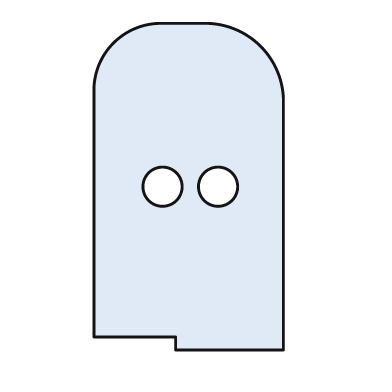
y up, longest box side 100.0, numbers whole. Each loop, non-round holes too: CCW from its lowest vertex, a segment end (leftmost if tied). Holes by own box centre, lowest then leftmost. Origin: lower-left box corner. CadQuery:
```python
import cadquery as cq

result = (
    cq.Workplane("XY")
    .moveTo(25.0, 0.0)
    .lineTo(58.0, 0.0)
    .lineTo(58.0, 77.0)
    .threePointArc((51.0, 93.0), (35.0, 100.0))
    .lineTo(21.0, 100.0)
    .threePointArc((6.0, 94.0), (0.0, 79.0))
    .lineTo(0.0, 4.0)
    .lineTo(25.0, 4.0)
    .close()
    .moveTo(21.0, 50.0)
    .circle(6.0)
    .moveTo(38.0, 50.0)
    .circle(6.0)
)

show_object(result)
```